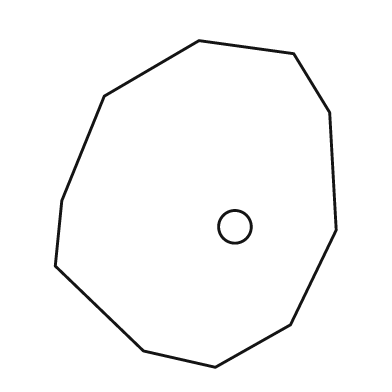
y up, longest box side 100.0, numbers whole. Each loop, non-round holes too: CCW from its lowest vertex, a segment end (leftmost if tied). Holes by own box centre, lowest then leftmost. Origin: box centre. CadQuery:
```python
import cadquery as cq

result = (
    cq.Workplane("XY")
    .moveTo(6.0, -50.0)
    .lineTo(29.0, -37.0)
    .lineTo(43.0, -8.0)
    .lineTo(41.0, 28.0)
    .lineTo(30.0, 46.0)
    .lineTo(1.0, 50.0)
    .lineTo(-28.0, 33.0)
    .lineTo(-41.0, 1.0)
    .lineTo(-43.0, -19.0)
    .lineTo(-16.0, -45.0)
    .close()
    .moveTo(12.0, -7.0)
    .circle(5.0)
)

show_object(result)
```